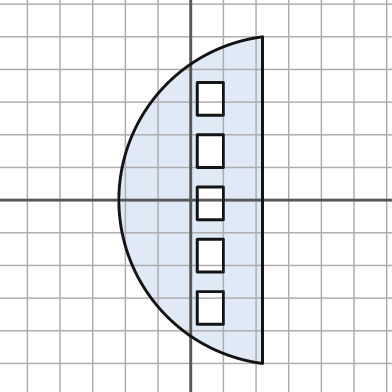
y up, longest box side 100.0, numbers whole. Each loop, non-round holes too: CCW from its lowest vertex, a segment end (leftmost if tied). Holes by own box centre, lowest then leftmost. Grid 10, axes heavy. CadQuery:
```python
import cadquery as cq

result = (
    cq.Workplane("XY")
    .moveTo(22.0, -50.0)
    .lineTo(22.0, 50.0)
    .threePointArc((-22.0, 0.0), (22.0, -50.0))
    .close()
    .moveTo(2.0, -38.0)
    .lineTo(10.0, -38.0)
    .lineTo(10.0, -28.0)
    .lineTo(2.0, -28.0)
    .close()
    .moveTo(2.0, -22.0)
    .lineTo(10.0, -22.0)
    .lineTo(10.0, -12.0)
    .lineTo(2.0, -12.0)
    .close()
    .moveTo(2.0, -6.0)
    .lineTo(10.0, -6.0)
    .lineTo(10.0, 4.0)
    .lineTo(2.0, 4.0)
    .close()
    .moveTo(2.0, 10.0)
    .lineTo(10.0, 10.0)
    .lineTo(10.0, 20.0)
    .lineTo(2.0, 20.0)
    .close()
    .moveTo(2.0, 26.0)
    .lineTo(10.0, 26.0)
    .lineTo(10.0, 36.0)
    .lineTo(2.0, 36.0)
    .close()
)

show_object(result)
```